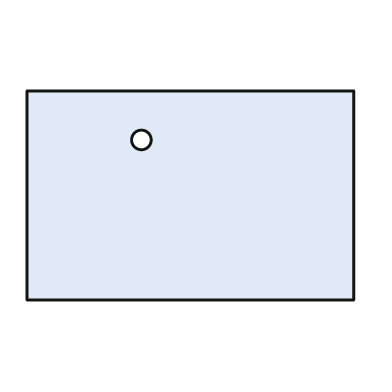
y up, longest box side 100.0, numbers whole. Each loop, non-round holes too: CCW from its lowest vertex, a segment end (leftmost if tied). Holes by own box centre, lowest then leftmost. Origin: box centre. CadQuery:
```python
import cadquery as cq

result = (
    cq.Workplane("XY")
    .moveTo(-50.0, -32.0)
    .lineTo(50.0, -32.0)
    .lineTo(50.0, 32.0)
    .lineTo(-50.0, 32.0)
    .close()
    .moveTo(-15.0, 17.0)
    .circle(3.0)
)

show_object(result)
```